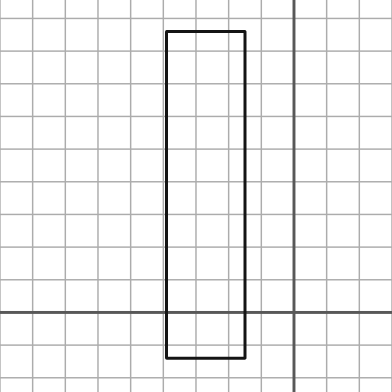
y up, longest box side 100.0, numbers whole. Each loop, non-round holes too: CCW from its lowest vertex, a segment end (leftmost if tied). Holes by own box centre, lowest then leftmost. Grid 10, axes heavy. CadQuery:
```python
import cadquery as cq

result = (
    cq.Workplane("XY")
    .moveTo(-39.0, -14.0)
    .lineTo(-15.0, -14.0)
    .lineTo(-15.0, 86.0)
    .lineTo(-39.0, 86.0)
    .close()
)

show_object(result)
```